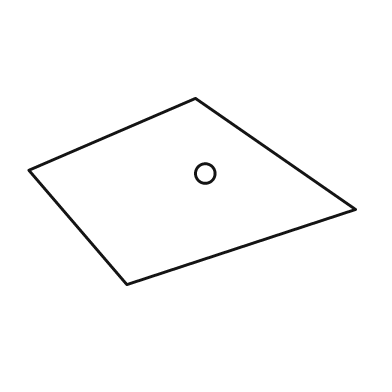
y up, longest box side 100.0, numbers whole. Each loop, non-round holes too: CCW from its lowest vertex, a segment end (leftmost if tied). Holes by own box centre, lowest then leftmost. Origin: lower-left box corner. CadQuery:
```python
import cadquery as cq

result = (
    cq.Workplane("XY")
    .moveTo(30.0, 0.0)
    .lineTo(100.0, 23.0)
    .lineTo(51.0, 57.0)
    .lineTo(0.0, 35.0)
    .close()
    .moveTo(54.0, 34.0)
    .circle(3.0)
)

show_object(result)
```